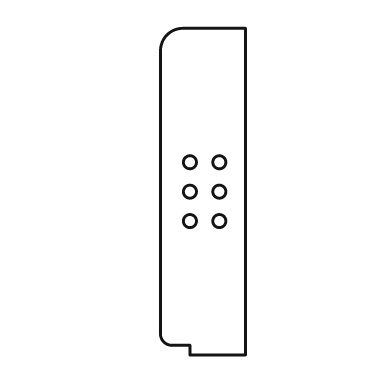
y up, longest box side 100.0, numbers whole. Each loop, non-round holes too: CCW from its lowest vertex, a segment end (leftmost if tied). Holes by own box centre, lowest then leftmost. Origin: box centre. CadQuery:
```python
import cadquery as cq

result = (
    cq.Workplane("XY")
    .moveTo(-4.0, -50.0)
    .lineTo(13.0, -50.0)
    .lineTo(13.0, 50.0)
    .lineTo(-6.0, 50.0)
    .threePointArc((-11.0, 48.0), (-13.0, 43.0))
    .lineTo(-13.0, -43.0)
    .threePointArc((-12.0, -46.0), (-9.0, -47.0))
    .lineTo(-4.0, -47.0)
    .close()
    .moveTo(-4.0, -9.0)
    .circle(2.0)
    .moveTo(5.0, -9.0)
    .circle(2.0)
    .moveTo(-4.0, 0.0)
    .circle(2.0)
    .moveTo(5.0, 0.0)
    .circle(2.0)
    .moveTo(-4.0, 9.0)
    .circle(2.0)
    .moveTo(5.0, 9.0)
    .circle(2.0)
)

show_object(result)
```